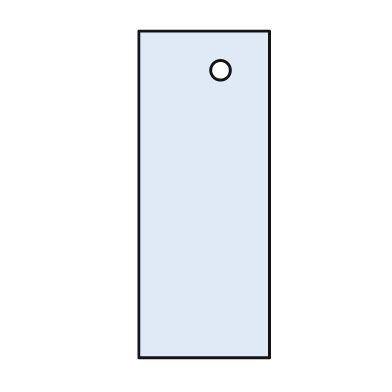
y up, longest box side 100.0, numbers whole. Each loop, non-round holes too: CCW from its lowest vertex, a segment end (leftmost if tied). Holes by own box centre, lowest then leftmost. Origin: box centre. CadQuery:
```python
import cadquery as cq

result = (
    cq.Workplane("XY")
    .moveTo(-20.0, -50.0)
    .lineTo(20.0, -50.0)
    .lineTo(20.0, 50.0)
    .lineTo(-20.0, 50.0)
    .close()
    .moveTo(5.0, 38.0)
    .circle(3.0)
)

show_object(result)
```